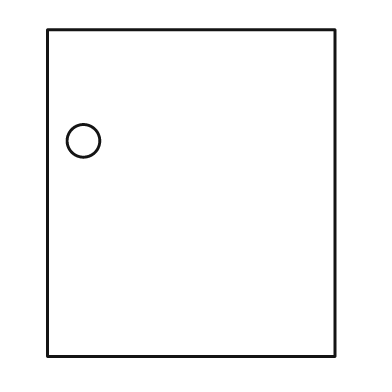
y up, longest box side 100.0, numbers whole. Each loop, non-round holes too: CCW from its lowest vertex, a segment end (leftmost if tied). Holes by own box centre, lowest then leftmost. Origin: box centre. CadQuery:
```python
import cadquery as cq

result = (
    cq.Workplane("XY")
    .moveTo(-44.0, -50.0)
    .lineTo(44.0, -50.0)
    .lineTo(44.0, 50.0)
    .lineTo(-44.0, 50.0)
    .close()
    .moveTo(-33.0, 16.0)
    .circle(5.0)
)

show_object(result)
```